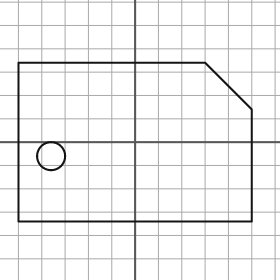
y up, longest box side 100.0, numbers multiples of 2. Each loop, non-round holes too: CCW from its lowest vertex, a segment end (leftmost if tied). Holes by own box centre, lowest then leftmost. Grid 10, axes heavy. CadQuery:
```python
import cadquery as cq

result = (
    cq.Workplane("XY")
    .moveTo(-50.0, -34.0)
    .lineTo(50.0, -34.0)
    .lineTo(50.0, 14.0)
    .lineTo(30.0, 34.0)
    .lineTo(-50.0, 34.0)
    .close()
    .moveTo(-36.0, -6.0)
    .circle(6.0)
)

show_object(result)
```